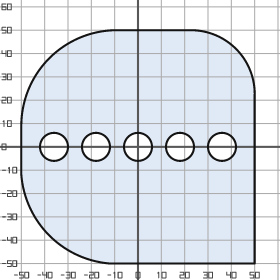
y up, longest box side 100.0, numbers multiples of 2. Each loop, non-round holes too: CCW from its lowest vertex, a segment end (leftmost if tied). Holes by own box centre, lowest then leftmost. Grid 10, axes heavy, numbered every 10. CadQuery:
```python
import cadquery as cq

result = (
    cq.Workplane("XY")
    .moveTo(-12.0, -50.0)
    .lineTo(50.0, -50.0)
    .lineTo(50.0, 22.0)
    .threePointArc((42.0, 42.0), (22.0, 50.0))
    .lineTo(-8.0, 50.0)
    .threePointArc((-38.0, 38.0), (-50.0, 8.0))
    .lineTo(-50.0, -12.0)
    .threePointArc((-38.0, -38.0), (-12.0, -50.0))
    .close()
    .moveTo(-36.0, 0.0)
    .circle(6.0)
    .moveTo(-18.0, 0.0)
    .circle(6.0)
    .moveTo(0.0, 0.0)
    .circle(6.0)
    .moveTo(18.0, 0.0)
    .circle(6.0)
    .moveTo(36.0, 0.0)
    .circle(6.0)
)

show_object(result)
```